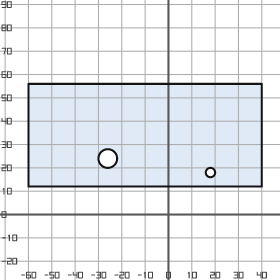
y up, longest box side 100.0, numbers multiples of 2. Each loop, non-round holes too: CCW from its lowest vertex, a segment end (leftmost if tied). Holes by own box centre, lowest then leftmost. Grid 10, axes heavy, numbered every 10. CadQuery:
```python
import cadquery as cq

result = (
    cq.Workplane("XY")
    .moveTo(-60.0, 12.0)
    .lineTo(40.0, 12.0)
    .lineTo(40.0, 56.0)
    .lineTo(-60.0, 56.0)
    .close()
    .moveTo(18.0, 18.0)
    .circle(2.0)
    .moveTo(-26.0, 24.0)
    .circle(4.0)
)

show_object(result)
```